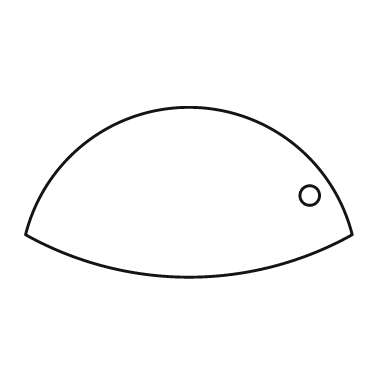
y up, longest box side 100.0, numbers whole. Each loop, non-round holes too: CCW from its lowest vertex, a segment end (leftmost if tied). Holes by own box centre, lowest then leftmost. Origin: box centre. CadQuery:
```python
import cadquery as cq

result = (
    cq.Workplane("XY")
    .moveTo(-50.0, -13.0)
    .threePointArc((0.0, -26.0), (50.0, -13.0))
    .threePointArc((0.0, 26.0), (-50.0, -13.0))
    .close()
    .moveTo(37.0, -1.0)
    .circle(3.0)
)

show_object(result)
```